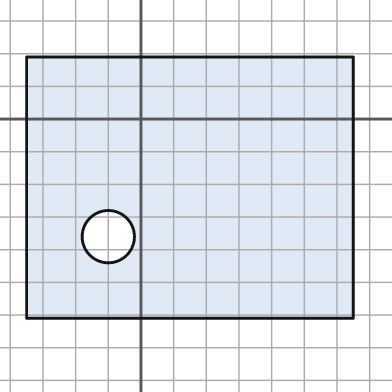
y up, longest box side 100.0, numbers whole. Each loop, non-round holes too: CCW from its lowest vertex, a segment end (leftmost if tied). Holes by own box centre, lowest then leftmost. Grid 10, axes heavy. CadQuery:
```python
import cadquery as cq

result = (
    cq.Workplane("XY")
    .moveTo(-35.0, -61.0)
    .lineTo(65.0, -61.0)
    .lineTo(65.0, 19.0)
    .lineTo(-35.0, 19.0)
    .close()
    .moveTo(-10.0, -36.0)
    .circle(8.0)
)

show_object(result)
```